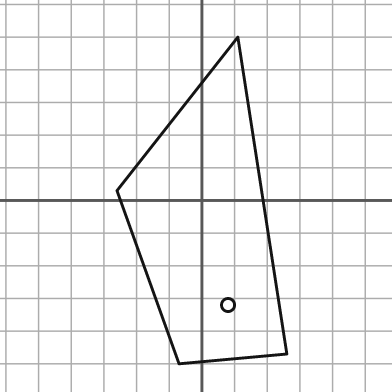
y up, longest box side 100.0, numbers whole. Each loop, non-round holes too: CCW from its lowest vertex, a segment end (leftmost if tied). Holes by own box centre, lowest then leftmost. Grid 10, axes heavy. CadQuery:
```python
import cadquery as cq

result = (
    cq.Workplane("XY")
    .moveTo(-7.0, -50.0)
    .lineTo(26.0, -47.0)
    .lineTo(11.0, 50.0)
    .lineTo(-26.0, 3.0)
    .close()
    .moveTo(8.0, -32.0)
    .circle(2.0)
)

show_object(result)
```